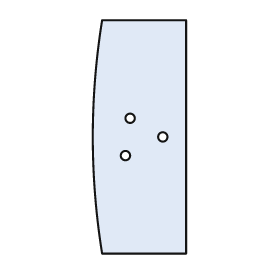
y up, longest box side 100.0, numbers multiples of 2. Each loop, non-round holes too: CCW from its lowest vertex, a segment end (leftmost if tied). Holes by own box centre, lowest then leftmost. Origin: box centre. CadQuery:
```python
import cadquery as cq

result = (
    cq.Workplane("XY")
    .moveTo(-16.0, -50.0)
    .lineTo(20.0, -50.0)
    .lineTo(20.0, 50.0)
    .lineTo(-16.0, 50.0)
    .threePointArc((-20.0, 0.0), (-16.0, -50.0))
    .close()
    .moveTo(-6.0, -8.0)
    .circle(2.0)
    .moveTo(10.0, 0.0)
    .circle(2.0)
    .moveTo(-4.0, 8.0)
    .circle(2.0)
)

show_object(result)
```